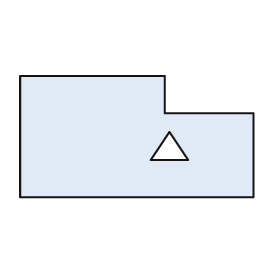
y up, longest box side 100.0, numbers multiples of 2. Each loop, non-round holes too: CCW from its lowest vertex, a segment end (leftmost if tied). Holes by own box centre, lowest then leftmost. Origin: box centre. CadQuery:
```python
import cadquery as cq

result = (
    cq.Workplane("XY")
    .moveTo(-50.0, -26.0)
    .lineTo(50.0, -26.0)
    .lineTo(50.0, 10.0)
    .lineTo(12.0, 10.0)
    .lineTo(12.0, 26.0)
    .lineTo(-50.0, 26.0)
    .close()
    .moveTo(6.0, -10.0)
    .lineTo(22.0, -10.0)
    .lineTo(14.0, 2.0)
    .close()
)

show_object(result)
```